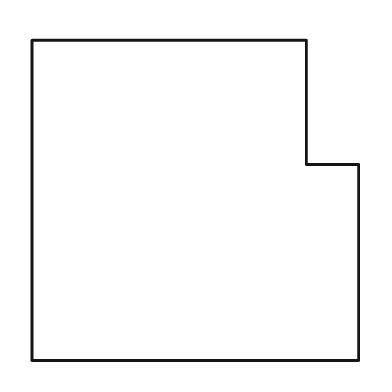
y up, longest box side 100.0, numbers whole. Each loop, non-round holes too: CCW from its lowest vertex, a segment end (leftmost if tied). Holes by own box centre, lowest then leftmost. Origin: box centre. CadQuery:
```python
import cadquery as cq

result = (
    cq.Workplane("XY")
    .moveTo(-50.0, -49.0)
    .lineTo(50.0, -49.0)
    .lineTo(50.0, 11.0)
    .lineTo(34.0, 11.0)
    .lineTo(34.0, 49.0)
    .lineTo(-50.0, 49.0)
    .close()
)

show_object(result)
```